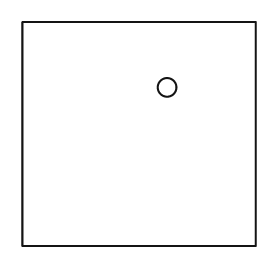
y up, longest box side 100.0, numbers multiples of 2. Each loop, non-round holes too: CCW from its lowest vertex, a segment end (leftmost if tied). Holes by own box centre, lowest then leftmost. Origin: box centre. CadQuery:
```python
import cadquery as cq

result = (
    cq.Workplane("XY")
    .moveTo(-50.0, -48.0)
    .lineTo(50.0, -48.0)
    .lineTo(50.0, 48.0)
    .lineTo(-50.0, 48.0)
    .close()
    .moveTo(12.0, 20.0)
    .circle(4.0)
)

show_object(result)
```